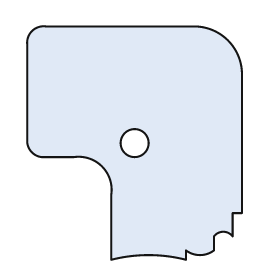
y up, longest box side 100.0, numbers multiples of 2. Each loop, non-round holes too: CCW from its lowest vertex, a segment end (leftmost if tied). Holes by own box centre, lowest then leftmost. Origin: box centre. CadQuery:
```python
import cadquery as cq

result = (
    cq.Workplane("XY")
    .moveTo(-10.0, -50.0)
    .threePointArc((6.0, -48.0), (22.0, -50.0))
    .lineTo(22.0, -46.0)
    .threePointArc((28.0, -48.0), (34.0, -46.0))
    .lineTo(34.0, -40.0)
    .threePointArc((38.0, -38.0), (42.0, -40.0))
    .lineTo(42.0, -30.0)
    .lineTo(46.0, -30.0)
    .lineTo(46.0, 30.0)
    .threePointArc((40.0, 44.0), (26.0, 50.0))
    .lineTo(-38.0, 50.0)
    .threePointArc((-44.0, 48.0), (-46.0, 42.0))
    .lineTo(-46.0, 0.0)
    .threePointArc((-44.0, -4.0), (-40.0, -6.0))
    .lineTo(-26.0, -6.0)
    .threePointArc((-14.0, -10.0), (-10.0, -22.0))
    .close()
    .moveTo(0.0, 0.0)
    .circle(6.0)
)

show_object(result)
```